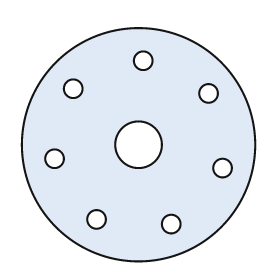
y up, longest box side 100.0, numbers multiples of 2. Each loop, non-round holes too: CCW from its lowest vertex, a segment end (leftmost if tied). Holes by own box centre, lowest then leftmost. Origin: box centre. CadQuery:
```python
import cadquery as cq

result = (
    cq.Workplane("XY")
    .moveTo(0.0, 0.0)
    .circle(50.0)
    .moveTo(14.0, -34.0)
    .circle(4.0)
    .moveTo(-18.0, -32.0)
    .circle(4.0)
    .moveTo(36.0, -10.0)
    .circle(4.0)
    .moveTo(-36.0, -6.0)
    .circle(4.0)
    .moveTo(0.0, 0.0)
    .circle(10.0)
    .moveTo(30.0, 22.0)
    .circle(4.0)
    .moveTo(-28.0, 24.0)
    .circle(4.0)
    .moveTo(2.0, 36.0)
    .circle(4.0)
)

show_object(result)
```